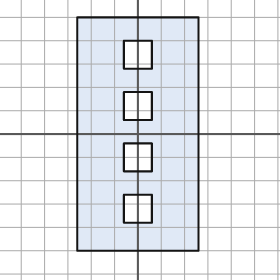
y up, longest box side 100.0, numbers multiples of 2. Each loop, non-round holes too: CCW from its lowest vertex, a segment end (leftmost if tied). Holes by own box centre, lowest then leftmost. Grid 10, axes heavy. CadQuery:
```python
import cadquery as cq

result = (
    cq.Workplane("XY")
    .moveTo(-26.0, -50.0)
    .lineTo(26.0, -50.0)
    .lineTo(26.0, 50.0)
    .lineTo(-26.0, 50.0)
    .close()
    .moveTo(-6.0, -38.0)
    .lineTo(6.0, -38.0)
    .lineTo(6.0, -26.0)
    .lineTo(-6.0, -26.0)
    .close()
    .moveTo(-6.0, -16.0)
    .lineTo(6.0, -16.0)
    .lineTo(6.0, -4.0)
    .lineTo(-6.0, -4.0)
    .close()
    .moveTo(-6.0, 6.0)
    .lineTo(6.0, 6.0)
    .lineTo(6.0, 18.0)
    .lineTo(-6.0, 18.0)
    .close()
    .moveTo(-6.0, 28.0)
    .lineTo(6.0, 28.0)
    .lineTo(6.0, 40.0)
    .lineTo(-6.0, 40.0)
    .close()
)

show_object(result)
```